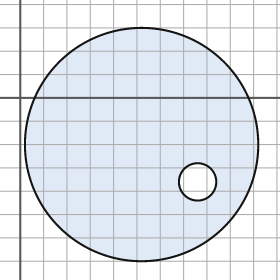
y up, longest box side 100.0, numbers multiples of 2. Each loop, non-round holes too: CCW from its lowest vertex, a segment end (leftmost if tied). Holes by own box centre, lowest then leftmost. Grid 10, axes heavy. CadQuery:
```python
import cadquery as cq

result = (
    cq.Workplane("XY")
    .moveTo(52.0, -20.0)
    .circle(50.0)
    .moveTo(76.0, -36.0)
    .circle(8.0)
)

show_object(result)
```